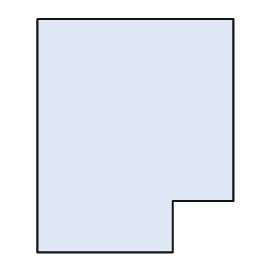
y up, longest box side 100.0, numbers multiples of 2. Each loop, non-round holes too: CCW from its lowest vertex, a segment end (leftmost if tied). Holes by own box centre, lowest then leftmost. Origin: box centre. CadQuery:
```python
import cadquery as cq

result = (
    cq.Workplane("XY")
    .moveTo(-42.0, -50.0)
    .lineTo(16.0, -50.0)
    .lineTo(16.0, -28.0)
    .lineTo(42.0, -28.0)
    .lineTo(42.0, 50.0)
    .lineTo(-42.0, 50.0)
    .close()
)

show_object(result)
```